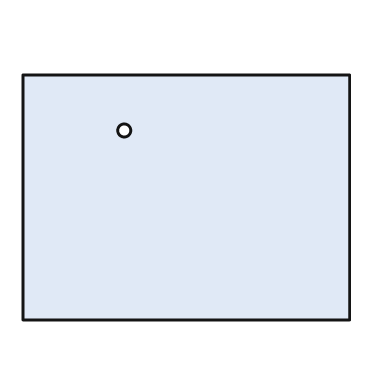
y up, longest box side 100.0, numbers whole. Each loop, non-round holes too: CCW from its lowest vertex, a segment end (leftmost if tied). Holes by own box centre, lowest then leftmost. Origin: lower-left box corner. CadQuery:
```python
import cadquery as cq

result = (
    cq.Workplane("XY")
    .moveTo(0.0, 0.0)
    .lineTo(100.0, 0.0)
    .lineTo(100.0, 75.0)
    .lineTo(0.0, 75.0)
    .close()
    .moveTo(31.0, 58.0)
    .circle(2.0)
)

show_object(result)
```